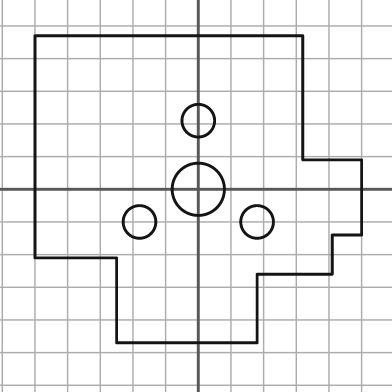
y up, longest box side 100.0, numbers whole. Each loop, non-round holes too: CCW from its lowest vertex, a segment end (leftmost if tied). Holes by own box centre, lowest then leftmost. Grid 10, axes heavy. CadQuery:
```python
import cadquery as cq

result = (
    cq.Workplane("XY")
    .moveTo(-25.0, -47.0)
    .lineTo(18.0, -47.0)
    .lineTo(18.0, -26.0)
    .lineTo(41.0, -26.0)
    .lineTo(41.0, -14.0)
    .lineTo(50.0, -14.0)
    .lineTo(50.0, 9.0)
    .lineTo(32.0, 9.0)
    .lineTo(32.0, 47.0)
    .lineTo(-50.0, 47.0)
    .lineTo(-50.0, -21.0)
    .lineTo(-25.0, -21.0)
    .close()
    .moveTo(-18.0, -10.0)
    .circle(5.0)
    .moveTo(18.0, -10.0)
    .circle(5.0)
    .moveTo(0.0, 0.0)
    .circle(8.0)
    .moveTo(0.0, 21.0)
    .circle(5.0)
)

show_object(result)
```